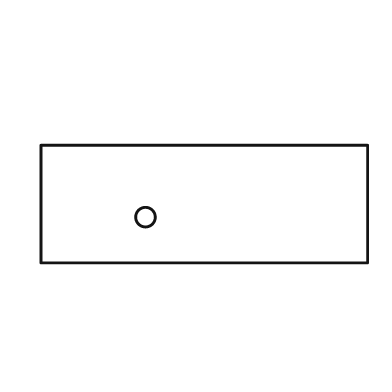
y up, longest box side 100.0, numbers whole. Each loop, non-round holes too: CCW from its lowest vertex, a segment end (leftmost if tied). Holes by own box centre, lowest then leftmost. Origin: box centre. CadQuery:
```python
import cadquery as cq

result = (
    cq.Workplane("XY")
    .moveTo(-50.0, -18.0)
    .lineTo(50.0, -18.0)
    .lineTo(50.0, 18.0)
    .lineTo(-50.0, 18.0)
    .close()
    .moveTo(-18.0, -4.0)
    .circle(3.0)
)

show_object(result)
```